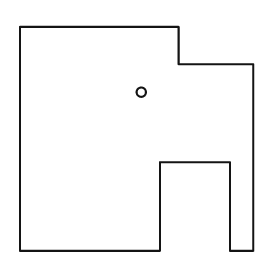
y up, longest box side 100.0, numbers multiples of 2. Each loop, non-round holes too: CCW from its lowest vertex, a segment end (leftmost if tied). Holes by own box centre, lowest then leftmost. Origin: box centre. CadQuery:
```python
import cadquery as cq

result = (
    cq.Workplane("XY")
    .moveTo(-50.0, -48.0)
    .lineTo(10.0, -48.0)
    .lineTo(10.0, -10.0)
    .lineTo(40.0, -10.0)
    .lineTo(40.0, -48.0)
    .lineTo(50.0, -48.0)
    .lineTo(50.0, 32.0)
    .lineTo(18.0, 32.0)
    .lineTo(18.0, 48.0)
    .lineTo(-50.0, 48.0)
    .close()
    .moveTo(2.0, 20.0)
    .circle(2.0)
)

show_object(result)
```